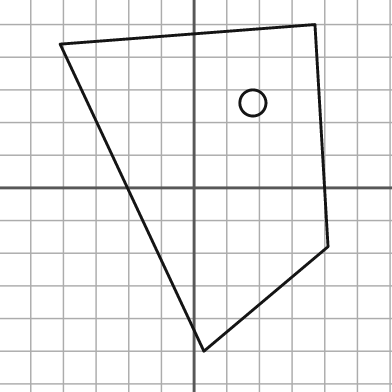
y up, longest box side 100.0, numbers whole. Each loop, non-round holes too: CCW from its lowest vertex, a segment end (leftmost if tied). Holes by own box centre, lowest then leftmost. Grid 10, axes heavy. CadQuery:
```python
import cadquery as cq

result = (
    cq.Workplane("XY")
    .moveTo(3.0, -50.0)
    .lineTo(41.0, -18.0)
    .lineTo(37.0, 50.0)
    .lineTo(-41.0, 44.0)
    .close()
    .moveTo(18.0, 26.0)
    .circle(4.0)
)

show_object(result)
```